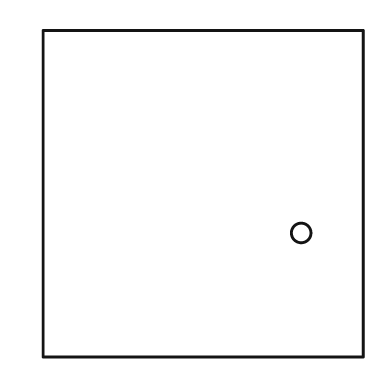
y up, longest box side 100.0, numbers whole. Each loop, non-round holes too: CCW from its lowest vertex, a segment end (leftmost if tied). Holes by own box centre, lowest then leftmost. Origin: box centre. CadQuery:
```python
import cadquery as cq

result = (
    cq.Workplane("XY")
    .moveTo(-49.0, -50.0)
    .lineTo(49.0, -50.0)
    .lineTo(49.0, 50.0)
    .lineTo(-49.0, 50.0)
    .close()
    .moveTo(30.0, -12.0)
    .circle(3.0)
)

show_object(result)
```